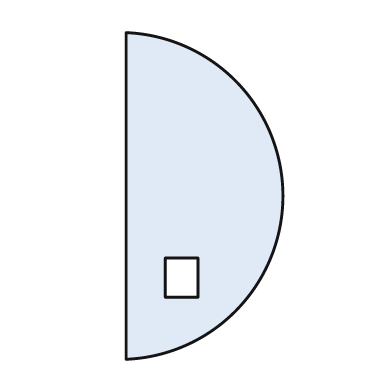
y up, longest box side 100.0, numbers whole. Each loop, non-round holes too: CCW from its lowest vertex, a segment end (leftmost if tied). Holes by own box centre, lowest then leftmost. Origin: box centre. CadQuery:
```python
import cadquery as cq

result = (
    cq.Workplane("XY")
    .moveTo(-24.0, -50.0)
    .threePointArc((24.0, 0.0), (-24.0, 50.0))
    .close()
    .moveTo(-12.0, -31.0)
    .lineTo(-2.0, -31.0)
    .lineTo(-2.0, -19.0)
    .lineTo(-12.0, -19.0)
    .close()
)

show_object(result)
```